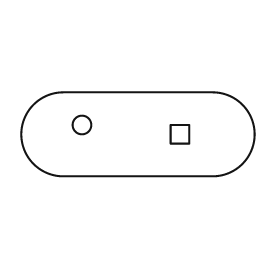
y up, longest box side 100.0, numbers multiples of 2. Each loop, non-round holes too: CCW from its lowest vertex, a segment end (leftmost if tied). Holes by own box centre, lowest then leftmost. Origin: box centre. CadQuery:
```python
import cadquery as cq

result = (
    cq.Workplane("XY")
    .moveTo(-32.0, -18.0)
    .lineTo(32.0, -18.0)
    .threePointArc((50.0, 0.0), (32.0, 18.0))
    .lineTo(-32.0, 18.0)
    .threePointArc((-50.0, 0.0), (-32.0, -18.0))
    .close()
    .moveTo(14.0, -4.0)
    .lineTo(22.0, -4.0)
    .lineTo(22.0, 4.0)
    .lineTo(14.0, 4.0)
    .close()
    .moveTo(-24.0, 4.0)
    .circle(4.0)
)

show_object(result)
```